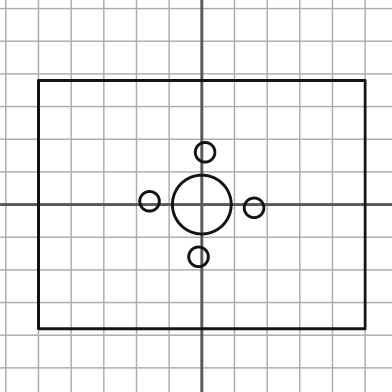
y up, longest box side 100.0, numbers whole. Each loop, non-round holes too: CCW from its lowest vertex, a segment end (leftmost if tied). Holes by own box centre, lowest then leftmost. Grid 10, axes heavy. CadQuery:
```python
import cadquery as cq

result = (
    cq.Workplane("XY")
    .moveTo(-50.0, -38.0)
    .lineTo(50.0, -38.0)
    .lineTo(50.0, 38.0)
    .lineTo(-50.0, 38.0)
    .close()
    .moveTo(-1.0, -16.0)
    .circle(3.0)
    .moveTo(16.0, -1.0)
    .circle(3.0)
    .moveTo(0.0, 0.0)
    .circle(9.0)
    .moveTo(-16.0, 1.0)
    .circle(3.0)
    .moveTo(1.0, 16.0)
    .circle(3.0)
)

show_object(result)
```